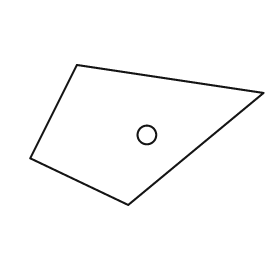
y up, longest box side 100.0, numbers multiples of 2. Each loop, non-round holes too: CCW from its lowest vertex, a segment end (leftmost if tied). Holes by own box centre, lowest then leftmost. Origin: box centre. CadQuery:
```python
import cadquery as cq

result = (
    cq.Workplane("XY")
    .moveTo(-8.0, -30.0)
    .lineTo(50.0, 18.0)
    .lineTo(-30.0, 30.0)
    .lineTo(-50.0, -10.0)
    .close()
    .moveTo(0.0, 0.0)
    .circle(4.0)
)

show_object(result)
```